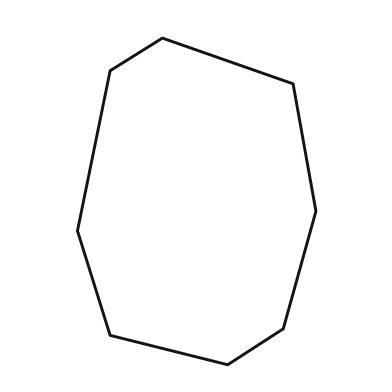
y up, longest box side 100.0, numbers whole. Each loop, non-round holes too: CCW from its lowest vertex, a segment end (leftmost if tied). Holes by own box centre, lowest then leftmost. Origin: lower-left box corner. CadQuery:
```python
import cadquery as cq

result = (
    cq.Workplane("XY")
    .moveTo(46.0, 0.0)
    .lineTo(63.0, 11.0)
    .lineTo(73.0, 47.0)
    .lineTo(66.0, 86.0)
    .lineTo(26.0, 100.0)
    .lineTo(10.0, 90.0)
    .lineTo(0.0, 41.0)
    .lineTo(10.0, 9.0)
    .close()
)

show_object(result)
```